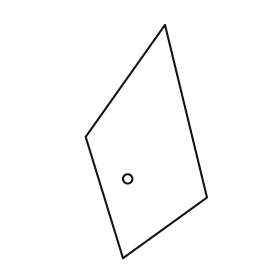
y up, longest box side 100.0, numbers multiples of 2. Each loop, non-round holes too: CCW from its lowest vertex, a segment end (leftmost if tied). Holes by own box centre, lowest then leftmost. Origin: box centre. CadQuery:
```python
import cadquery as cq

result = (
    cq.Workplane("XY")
    .moveTo(-10.0, -50.0)
    .lineTo(26.0, -24.0)
    .lineTo(8.0, 50.0)
    .lineTo(-26.0, 2.0)
    .close()
    .moveTo(-8.0, -16.0)
    .circle(2.0)
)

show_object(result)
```